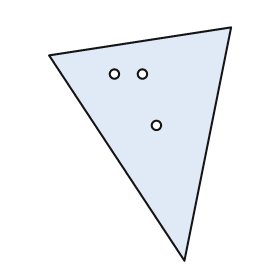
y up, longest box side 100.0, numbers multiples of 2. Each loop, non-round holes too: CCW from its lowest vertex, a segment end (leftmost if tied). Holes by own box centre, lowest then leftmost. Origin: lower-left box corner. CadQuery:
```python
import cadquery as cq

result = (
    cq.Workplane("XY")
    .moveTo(58.0, 0.0)
    .lineTo(78.0, 100.0)
    .lineTo(0.0, 88.0)
    .close()
    .moveTo(46.0, 58.0)
    .circle(2.0)
    .moveTo(28.0, 80.0)
    .circle(2.0)
    .moveTo(40.0, 80.0)
    .circle(2.0)
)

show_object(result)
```